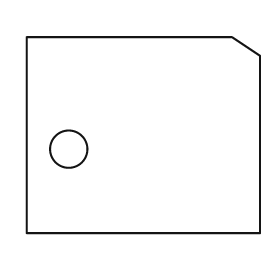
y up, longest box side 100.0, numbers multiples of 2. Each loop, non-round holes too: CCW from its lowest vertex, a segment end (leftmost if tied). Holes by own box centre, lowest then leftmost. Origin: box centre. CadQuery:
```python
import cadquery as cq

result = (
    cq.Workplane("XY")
    .moveTo(-50.0, -42.0)
    .lineTo(50.0, -42.0)
    .lineTo(50.0, 34.0)
    .lineTo(38.0, 42.0)
    .lineTo(-50.0, 42.0)
    .close()
    .moveTo(-32.0, -6.0)
    .circle(8.0)
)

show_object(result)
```